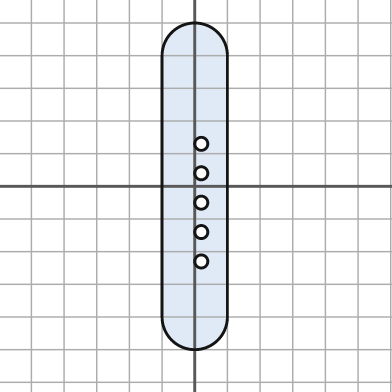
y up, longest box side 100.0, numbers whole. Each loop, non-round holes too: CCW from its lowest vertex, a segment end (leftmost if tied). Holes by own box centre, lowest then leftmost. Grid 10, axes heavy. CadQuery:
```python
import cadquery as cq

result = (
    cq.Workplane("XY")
    .moveTo(-10.0, -40.0)
    .threePointArc((0.0, -50.0), (10.0, -40.0))
    .lineTo(10.0, 40.0)
    .threePointArc((0.0, 50.0), (-10.0, 40.0))
    .close()
    .moveTo(2.0, -23.0)
    .circle(2.0)
    .moveTo(2.0, -14.0)
    .circle(2.0)
    .moveTo(2.0, -5.0)
    .circle(2.0)
    .moveTo(2.0, 4.0)
    .circle(2.0)
    .moveTo(2.0, 13.0)
    .circle(2.0)
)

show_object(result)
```